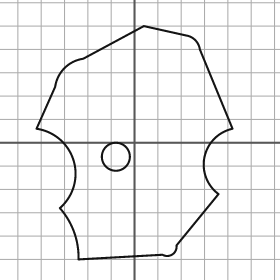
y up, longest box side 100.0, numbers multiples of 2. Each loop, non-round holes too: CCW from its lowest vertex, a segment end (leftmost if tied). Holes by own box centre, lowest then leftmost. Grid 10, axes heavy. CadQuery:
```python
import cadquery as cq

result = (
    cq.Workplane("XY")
    .moveTo(-24.0, -50.0)
    .lineTo(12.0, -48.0)
    .threePointArc((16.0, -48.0), (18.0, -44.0))
    .lineTo(36.0, -22.0)
    .threePointArc((30.0, -6.0), (42.0, 6.0))
    .lineTo(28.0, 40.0)
    .threePointArc((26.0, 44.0), (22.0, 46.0))
    .lineTo(4.0, 50.0)
    .lineTo(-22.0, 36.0)
    .threePointArc((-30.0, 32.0), (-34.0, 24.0))
    .lineTo(-42.0, 6.0)
    .threePointArc((-26.0, -8.0), (-32.0, -28.0))
    .threePointArc((-26.0, -38.0), (-24.0, -50.0))
    .close()
    .moveTo(-8.0, -6.0)
    .circle(6.0)
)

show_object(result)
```